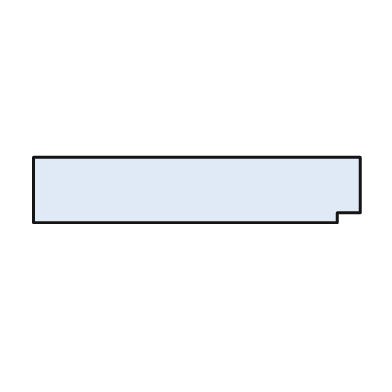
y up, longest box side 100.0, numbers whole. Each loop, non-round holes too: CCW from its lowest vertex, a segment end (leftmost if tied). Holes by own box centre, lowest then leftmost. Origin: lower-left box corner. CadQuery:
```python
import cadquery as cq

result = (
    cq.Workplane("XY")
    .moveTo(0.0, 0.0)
    .lineTo(93.0, 0.0)
    .lineTo(93.0, 3.0)
    .lineTo(100.0, 3.0)
    .lineTo(100.0, 20.0)
    .lineTo(0.0, 20.0)
    .close()
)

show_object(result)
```